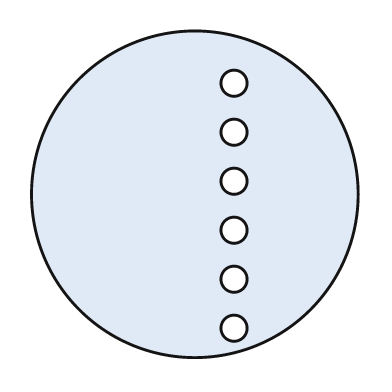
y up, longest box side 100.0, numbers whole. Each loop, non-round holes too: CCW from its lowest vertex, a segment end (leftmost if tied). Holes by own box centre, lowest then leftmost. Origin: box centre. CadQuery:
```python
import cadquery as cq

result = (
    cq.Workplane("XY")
    .moveTo(0.0, 0.0)
    .circle(50.0)
    .moveTo(12.0, -41.0)
    .circle(4.0)
    .moveTo(12.0, -26.0)
    .circle(4.0)
    .moveTo(12.0, -11.0)
    .circle(4.0)
    .moveTo(12.0, 4.0)
    .circle(4.0)
    .moveTo(12.0, 19.0)
    .circle(4.0)
    .moveTo(12.0, 34.0)
    .circle(4.0)
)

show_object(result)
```